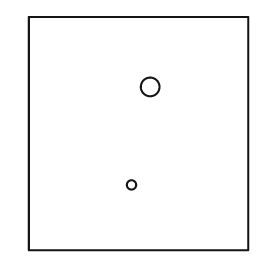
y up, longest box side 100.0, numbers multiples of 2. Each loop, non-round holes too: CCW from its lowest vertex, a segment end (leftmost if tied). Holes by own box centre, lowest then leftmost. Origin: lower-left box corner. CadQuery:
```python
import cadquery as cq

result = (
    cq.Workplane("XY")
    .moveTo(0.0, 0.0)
    .lineTo(94.0, 0.0)
    .lineTo(94.0, 100.0)
    .lineTo(0.0, 100.0)
    .close()
    .moveTo(44.0, 28.0)
    .circle(2.0)
    .moveTo(52.0, 70.0)
    .circle(4.0)
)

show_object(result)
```